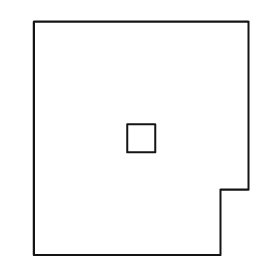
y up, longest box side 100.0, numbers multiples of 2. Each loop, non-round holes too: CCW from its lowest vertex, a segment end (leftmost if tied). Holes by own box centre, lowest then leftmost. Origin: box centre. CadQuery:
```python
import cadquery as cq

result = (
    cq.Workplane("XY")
    .moveTo(-46.0, -50.0)
    .lineTo(34.0, -50.0)
    .lineTo(34.0, -22.0)
    .lineTo(46.0, -22.0)
    .lineTo(46.0, 50.0)
    .lineTo(-46.0, 50.0)
    .close()
    .moveTo(-6.0, -6.0)
    .lineTo(6.0, -6.0)
    .lineTo(6.0, 6.0)
    .lineTo(-6.0, 6.0)
    .close()
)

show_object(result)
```